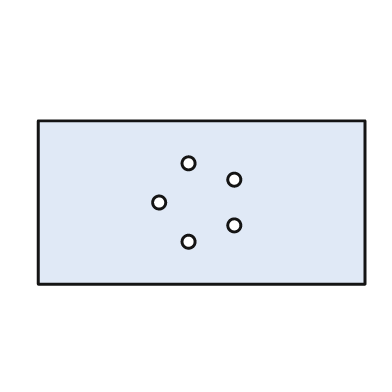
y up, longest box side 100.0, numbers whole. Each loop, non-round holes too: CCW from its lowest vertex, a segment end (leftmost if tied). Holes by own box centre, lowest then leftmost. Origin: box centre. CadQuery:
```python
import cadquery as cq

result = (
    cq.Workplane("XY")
    .moveTo(-50.0, -25.0)
    .lineTo(50.0, -25.0)
    .lineTo(50.0, 25.0)
    .lineTo(-50.0, 25.0)
    .close()
    .moveTo(-4.0, -12.0)
    .circle(2.0)
    .moveTo(10.0, -7.0)
    .circle(2.0)
    .moveTo(-13.0, 0.0)
    .circle(2.0)
    .moveTo(10.0, 7.0)
    .circle(2.0)
    .moveTo(-4.0, 12.0)
    .circle(2.0)
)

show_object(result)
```